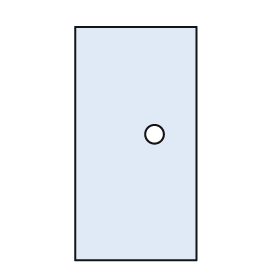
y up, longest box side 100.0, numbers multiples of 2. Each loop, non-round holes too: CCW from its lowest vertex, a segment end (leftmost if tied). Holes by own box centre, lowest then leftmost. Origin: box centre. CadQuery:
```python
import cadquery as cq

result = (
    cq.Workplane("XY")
    .moveTo(-26.0, -50.0)
    .lineTo(26.0, -50.0)
    .lineTo(26.0, 50.0)
    .lineTo(-26.0, 50.0)
    .close()
    .moveTo(8.0, 4.0)
    .circle(4.0)
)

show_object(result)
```